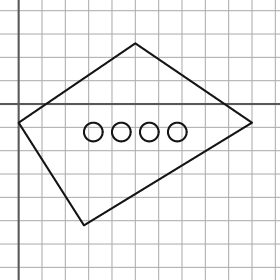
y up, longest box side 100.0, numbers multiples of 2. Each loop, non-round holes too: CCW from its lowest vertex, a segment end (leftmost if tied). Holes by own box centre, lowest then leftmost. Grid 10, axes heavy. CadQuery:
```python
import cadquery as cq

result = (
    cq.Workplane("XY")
    .moveTo(28.0, -52.0)
    .lineTo(100.0, -8.0)
    .lineTo(50.0, 26.0)
    .lineTo(0.0, -8.0)
    .close()
    .moveTo(32.0, -12.0)
    .circle(4.0)
    .moveTo(44.0, -12.0)
    .circle(4.0)
    .moveTo(56.0, -12.0)
    .circle(4.0)
    .moveTo(68.0, -12.0)
    .circle(4.0)
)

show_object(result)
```